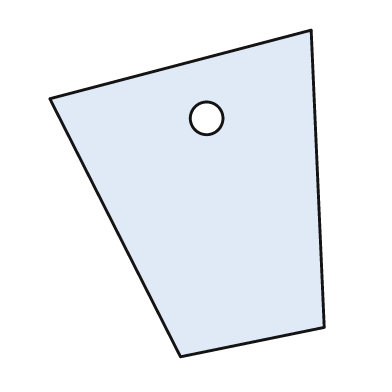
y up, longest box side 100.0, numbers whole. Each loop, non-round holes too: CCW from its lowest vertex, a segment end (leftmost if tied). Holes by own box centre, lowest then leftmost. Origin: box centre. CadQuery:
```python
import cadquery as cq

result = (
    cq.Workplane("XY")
    .moveTo(-2.0, -50.0)
    .lineTo(42.0, -41.0)
    .lineTo(38.0, 50.0)
    .lineTo(-42.0, 29.0)
    .close()
    .moveTo(6.0, 23.0)
    .circle(5.0)
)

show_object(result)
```